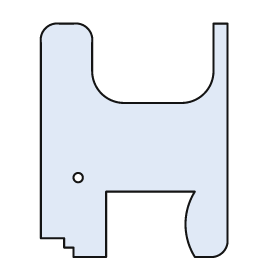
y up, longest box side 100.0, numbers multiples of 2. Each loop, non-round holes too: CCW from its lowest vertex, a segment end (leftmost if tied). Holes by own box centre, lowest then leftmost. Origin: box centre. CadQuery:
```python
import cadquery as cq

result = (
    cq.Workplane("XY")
    .moveTo(-26.0, -50.0)
    .lineTo(-12.0, -50.0)
    .lineTo(-12.0, -22.0)
    .lineTo(26.0, -22.0)
    .threePointArc((22.0, -36.0), (26.0, -50.0))
    .lineTo(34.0, -50.0)
    .threePointArc((38.0, -48.0), (40.0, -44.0))
    .lineTo(40.0, 50.0)
    .lineTo(34.0, 50.0)
    .lineTo(34.0, 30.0)
    .threePointArc((30.0, 20.0), (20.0, 16.0))
    .lineTo(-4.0, 16.0)
    .threePointArc((-14.0, 20.0), (-18.0, 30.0))
    .lineTo(-18.0, 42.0)
    .threePointArc((-20.0, 48.0), (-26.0, 50.0))
    .lineTo(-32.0, 50.0)
    .threePointArc((-38.0, 48.0), (-40.0, 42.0))
    .lineTo(-40.0, -42.0)
    .lineTo(-30.0, -42.0)
    .lineTo(-30.0, -46.0)
    .lineTo(-26.0, -46.0)
    .close()
    .moveTo(-24.0, -16.0)
    .circle(2.0)
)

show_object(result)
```